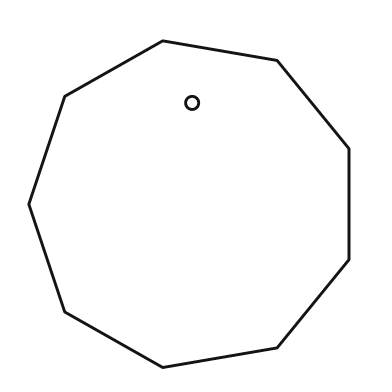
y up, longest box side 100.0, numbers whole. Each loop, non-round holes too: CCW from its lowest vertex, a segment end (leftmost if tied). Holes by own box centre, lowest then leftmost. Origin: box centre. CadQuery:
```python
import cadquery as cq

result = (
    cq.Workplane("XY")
    .moveTo(-8.0, -50.0)
    .lineTo(27.0, -44.0)
    .lineTo(49.0, -17.0)
    .lineTo(49.0, 17.0)
    .lineTo(27.0, 44.0)
    .lineTo(-8.0, 50.0)
    .lineTo(-38.0, 33.0)
    .lineTo(-49.0, 0.0)
    .lineTo(-38.0, -33.0)
    .close()
    .moveTo(1.0, 31.0)
    .circle(2.0)
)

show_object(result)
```